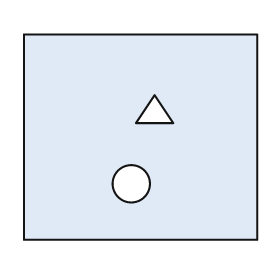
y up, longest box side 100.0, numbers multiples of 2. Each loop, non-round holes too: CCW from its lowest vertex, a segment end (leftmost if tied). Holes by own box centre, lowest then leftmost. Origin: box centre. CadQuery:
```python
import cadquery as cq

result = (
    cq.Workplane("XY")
    .moveTo(-50.0, -44.0)
    .lineTo(50.0, -44.0)
    .lineTo(50.0, 44.0)
    .lineTo(-50.0, 44.0)
    .close()
    .moveTo(-4.0, -20.0)
    .circle(8.0)
    .moveTo(-2.0, 6.0)
    .lineTo(14.0, 6.0)
    .lineTo(6.0, 18.0)
    .close()
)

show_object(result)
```